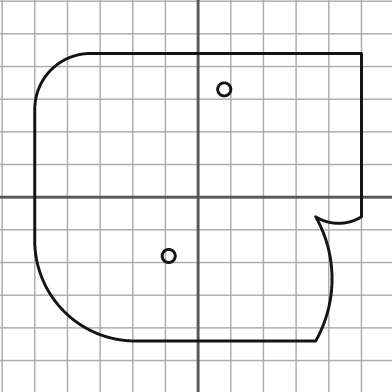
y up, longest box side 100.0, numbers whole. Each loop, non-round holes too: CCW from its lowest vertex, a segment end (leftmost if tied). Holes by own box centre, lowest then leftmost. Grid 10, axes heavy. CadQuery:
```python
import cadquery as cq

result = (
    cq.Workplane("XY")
    .moveTo(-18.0, -44.0)
    .lineTo(36.0, -44.0)
    .threePointArc((41.0, -25.0), (36.0, -6.0))
    .threePointArc((43.0, -8.0), (50.0, -6.0))
    .lineTo(50.0, 44.0)
    .lineTo(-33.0, 44.0)
    .threePointArc((-45.0, 39.0), (-50.0, 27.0))
    .lineTo(-50.0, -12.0)
    .threePointArc((-41.0, -35.0), (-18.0, -44.0))
    .close()
    .moveTo(-9.0, -18.0)
    .circle(2.0)
    .moveTo(8.0, 33.0)
    .circle(2.0)
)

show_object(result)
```